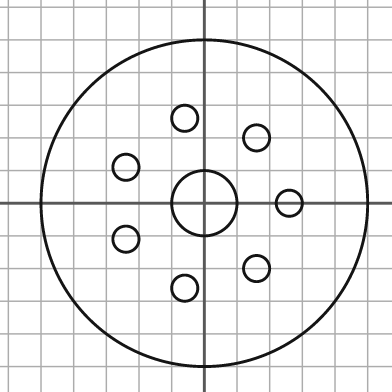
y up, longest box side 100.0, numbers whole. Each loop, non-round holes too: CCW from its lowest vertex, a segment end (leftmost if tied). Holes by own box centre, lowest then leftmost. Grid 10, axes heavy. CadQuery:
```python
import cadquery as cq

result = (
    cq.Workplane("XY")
    .moveTo(0.0, 0.0)
    .circle(50.0)
    .moveTo(-6.0, -26.0)
    .circle(4.0)
    .moveTo(16.0, -20.0)
    .circle(4.0)
    .moveTo(-24.0, -11.0)
    .circle(4.0)
    .moveTo(0.0, 0.0)
    .circle(10.0)
    .moveTo(26.0, 0.0)
    .circle(4.0)
    .moveTo(-24.0, 11.0)
    .circle(4.0)
    .moveTo(16.0, 20.0)
    .circle(4.0)
    .moveTo(-6.0, 26.0)
    .circle(4.0)
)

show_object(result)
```